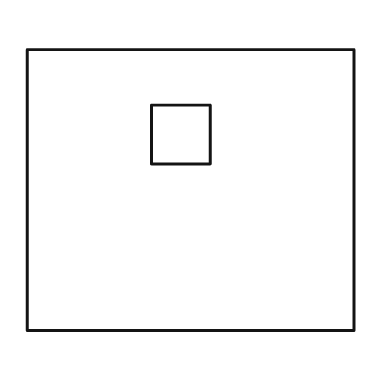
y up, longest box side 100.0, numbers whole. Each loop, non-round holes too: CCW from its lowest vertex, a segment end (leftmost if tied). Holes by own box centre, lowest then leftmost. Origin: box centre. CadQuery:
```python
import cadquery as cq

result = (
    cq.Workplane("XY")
    .moveTo(-50.0, -43.0)
    .lineTo(50.0, -43.0)
    .lineTo(50.0, 43.0)
    .lineTo(-50.0, 43.0)
    .close()
    .moveTo(-12.0, 8.0)
    .lineTo(6.0, 8.0)
    .lineTo(6.0, 26.0)
    .lineTo(-12.0, 26.0)
    .close()
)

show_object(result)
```